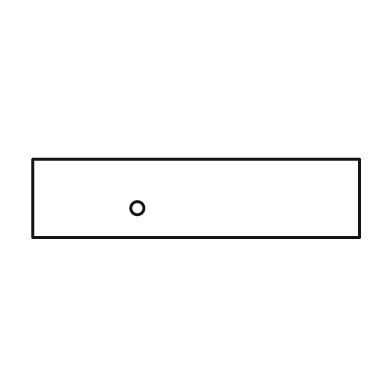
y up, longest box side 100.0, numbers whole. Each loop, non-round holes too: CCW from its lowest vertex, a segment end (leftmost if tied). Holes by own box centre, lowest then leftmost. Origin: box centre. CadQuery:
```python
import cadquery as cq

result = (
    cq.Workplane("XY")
    .moveTo(-50.0, -12.0)
    .lineTo(50.0, -12.0)
    .lineTo(50.0, 12.0)
    .lineTo(-50.0, 12.0)
    .close()
    .moveTo(-18.0, -3.0)
    .circle(2.0)
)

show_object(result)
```